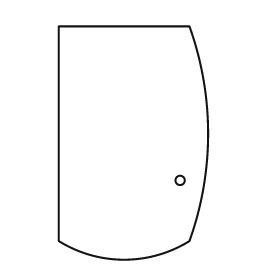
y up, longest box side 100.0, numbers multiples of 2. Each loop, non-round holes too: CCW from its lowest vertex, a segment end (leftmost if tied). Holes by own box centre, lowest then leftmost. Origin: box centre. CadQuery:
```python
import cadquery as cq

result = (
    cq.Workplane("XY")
    .moveTo(-32.0, -42.0)
    .threePointArc((-4.0, -50.0), (24.0, -42.0))
    .threePointArc((32.0, 4.0), (24.0, 50.0))
    .lineTo(-32.0, 50.0)
    .close()
    .moveTo(20.0, -16.0)
    .circle(2.0)
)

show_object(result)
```